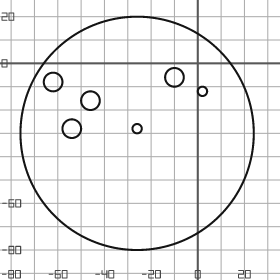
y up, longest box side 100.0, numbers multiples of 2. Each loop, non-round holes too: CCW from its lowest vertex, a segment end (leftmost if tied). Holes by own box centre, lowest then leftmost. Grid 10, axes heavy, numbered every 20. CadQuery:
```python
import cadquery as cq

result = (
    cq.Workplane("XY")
    .moveTo(-26.0, -30.0)
    .circle(50.0)
    .moveTo(-54.0, -28.0)
    .circle(4.0)
    .moveTo(-26.0, -28.0)
    .circle(2.0)
    .moveTo(-46.0, -16.0)
    .circle(4.0)
    .moveTo(2.0, -12.0)
    .circle(2.0)
    .moveTo(-62.0, -8.0)
    .circle(4.0)
    .moveTo(-10.0, -6.0)
    .circle(4.0)
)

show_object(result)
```